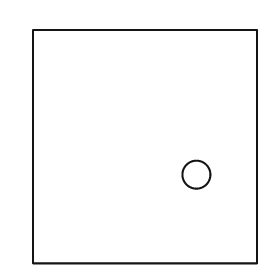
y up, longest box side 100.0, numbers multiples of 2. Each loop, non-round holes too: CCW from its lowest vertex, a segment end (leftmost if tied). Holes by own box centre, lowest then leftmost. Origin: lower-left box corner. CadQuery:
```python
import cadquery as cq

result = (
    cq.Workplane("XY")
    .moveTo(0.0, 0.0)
    .lineTo(96.0, 0.0)
    .lineTo(96.0, 100.0)
    .lineTo(0.0, 100.0)
    .close()
    .moveTo(70.0, 38.0)
    .circle(6.0)
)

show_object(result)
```